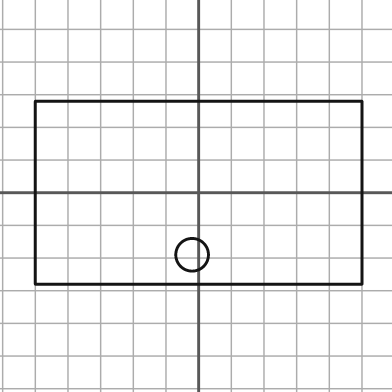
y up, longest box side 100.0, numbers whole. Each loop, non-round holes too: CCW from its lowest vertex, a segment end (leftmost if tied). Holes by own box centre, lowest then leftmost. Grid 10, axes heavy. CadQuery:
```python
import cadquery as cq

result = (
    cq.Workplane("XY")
    .moveTo(-50.0, -28.0)
    .lineTo(50.0, -28.0)
    .lineTo(50.0, 28.0)
    .lineTo(-50.0, 28.0)
    .close()
    .moveTo(-2.0, -19.0)
    .circle(5.0)
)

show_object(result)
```